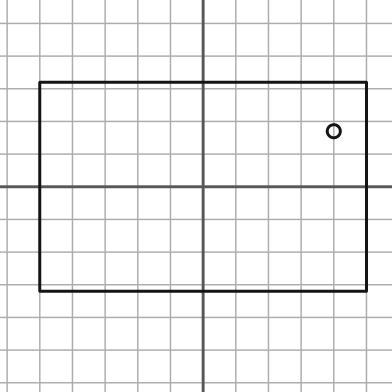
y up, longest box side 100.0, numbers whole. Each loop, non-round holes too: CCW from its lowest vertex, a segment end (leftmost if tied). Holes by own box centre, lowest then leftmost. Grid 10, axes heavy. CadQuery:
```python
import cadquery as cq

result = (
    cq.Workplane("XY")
    .moveTo(-50.0, -32.0)
    .lineTo(50.0, -32.0)
    .lineTo(50.0, 32.0)
    .lineTo(-50.0, 32.0)
    .close()
    .moveTo(40.0, 17.0)
    .circle(2.0)
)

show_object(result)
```